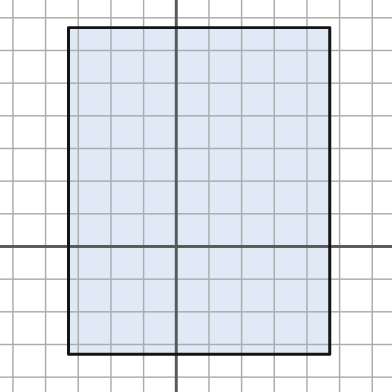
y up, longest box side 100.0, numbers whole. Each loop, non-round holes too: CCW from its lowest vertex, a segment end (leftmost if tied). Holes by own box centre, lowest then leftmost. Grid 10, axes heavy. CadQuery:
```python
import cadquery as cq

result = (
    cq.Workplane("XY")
    .moveTo(-33.0, -33.0)
    .lineTo(47.0, -33.0)
    .lineTo(47.0, 67.0)
    .lineTo(-33.0, 67.0)
    .close()
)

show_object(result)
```